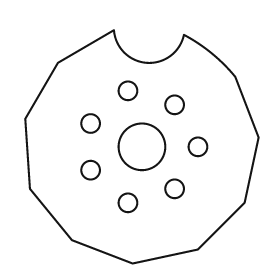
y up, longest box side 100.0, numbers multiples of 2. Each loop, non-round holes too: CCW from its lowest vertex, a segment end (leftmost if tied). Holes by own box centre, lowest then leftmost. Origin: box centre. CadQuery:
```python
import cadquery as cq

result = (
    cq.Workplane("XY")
    .moveTo(-4.0, -50.0)
    .lineTo(24.0, -44.0)
    .lineTo(44.0, -24.0)
    .lineTo(50.0, 4.0)
    .lineTo(40.0, 30.0)
    .threePointArc((30.0, 40.0), (18.0, 48.0))
    .threePointArc((2.0, 36.0), (-12.0, 50.0))
    .lineTo(-36.0, 36.0)
    .lineTo(-50.0, 12.0)
    .lineTo(-48.0, -18.0)
    .lineTo(-30.0, -40.0)
    .close()
    .moveTo(-6.0, -24.0)
    .circle(4.0)
    .moveTo(14.0, -18.0)
    .circle(4.0)
    .moveTo(-22.0, -10.0)
    .circle(4.0)
    .moveTo(0.0, 0.0)
    .circle(10.0)
    .moveTo(24.0, 0.0)
    .circle(4.0)
    .moveTo(-22.0, 10.0)
    .circle(4.0)
    .moveTo(14.0, 18.0)
    .circle(4.0)
    .moveTo(-6.0, 24.0)
    .circle(4.0)
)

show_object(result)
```